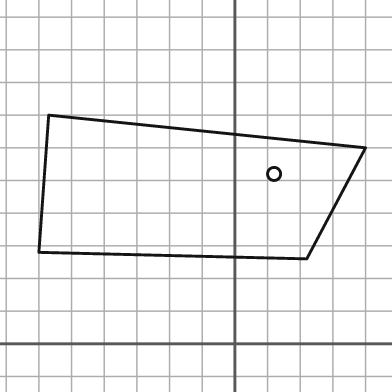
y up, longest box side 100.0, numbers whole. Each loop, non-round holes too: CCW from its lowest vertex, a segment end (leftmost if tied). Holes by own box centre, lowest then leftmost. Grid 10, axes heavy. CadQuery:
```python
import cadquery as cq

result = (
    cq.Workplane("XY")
    .moveTo(22.0, 26.0)
    .lineTo(40.0, 60.0)
    .lineTo(-57.0, 70.0)
    .lineTo(-60.0, 28.0)
    .close()
    .moveTo(12.0, 52.0)
    .circle(2.0)
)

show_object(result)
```